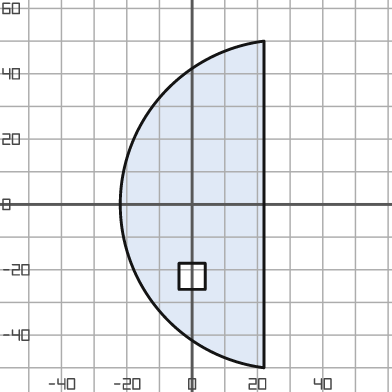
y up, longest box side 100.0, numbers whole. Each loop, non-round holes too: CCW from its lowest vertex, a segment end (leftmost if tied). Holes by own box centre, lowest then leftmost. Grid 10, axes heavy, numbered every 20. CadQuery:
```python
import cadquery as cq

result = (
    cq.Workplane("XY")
    .moveTo(22.0, -50.0)
    .lineTo(22.0, 50.0)
    .threePointArc((-22.0, 0.0), (22.0, -50.0))
    .close()
    .moveTo(-4.0, -26.0)
    .lineTo(4.0, -26.0)
    .lineTo(4.0, -18.0)
    .lineTo(-4.0, -18.0)
    .close()
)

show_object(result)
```